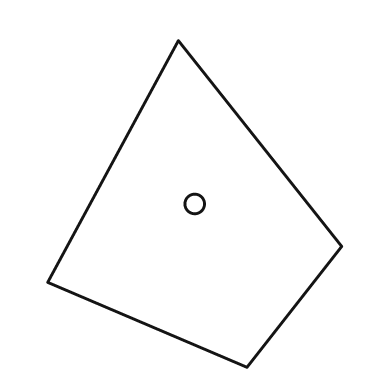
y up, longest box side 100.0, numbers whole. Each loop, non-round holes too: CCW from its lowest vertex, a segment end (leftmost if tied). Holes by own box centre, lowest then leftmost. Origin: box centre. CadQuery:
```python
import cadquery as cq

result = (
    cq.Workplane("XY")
    .moveTo(16.0, -50.0)
    .lineTo(45.0, -13.0)
    .lineTo(-5.0, 50.0)
    .lineTo(-45.0, -24.0)
    .close()
    .moveTo(0.0, 0.0)
    .circle(3.0)
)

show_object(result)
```